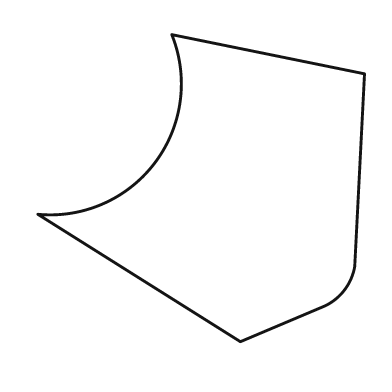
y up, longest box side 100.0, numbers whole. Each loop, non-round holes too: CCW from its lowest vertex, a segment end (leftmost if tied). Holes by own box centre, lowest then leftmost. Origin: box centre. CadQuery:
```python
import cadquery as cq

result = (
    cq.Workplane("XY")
    .moveTo(12.0, -47.0)
    .lineTo(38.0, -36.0)
    .threePointArc((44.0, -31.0), (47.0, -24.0))
    .lineTo(50.0, 35.0)
    .lineTo(-9.0, 47.0)
    .threePointArc((-14.0, 8.0), (-50.0, -8.0))
    .close()
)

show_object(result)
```